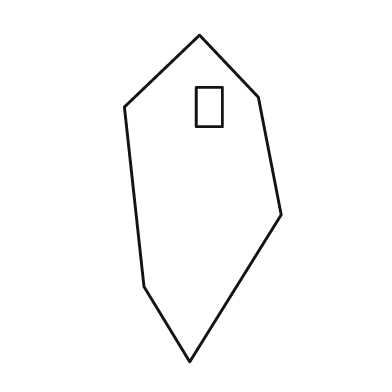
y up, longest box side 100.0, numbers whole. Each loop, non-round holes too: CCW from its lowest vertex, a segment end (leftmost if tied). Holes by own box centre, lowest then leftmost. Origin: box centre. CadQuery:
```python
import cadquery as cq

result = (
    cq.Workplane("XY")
    .moveTo(-4.0, -50.0)
    .lineTo(24.0, -5.0)
    .lineTo(17.0, 31.0)
    .lineTo(-1.0, 50.0)
    .lineTo(-24.0, 28.0)
    .lineTo(-18.0, -27.0)
    .close()
    .moveTo(-2.0, 22.0)
    .lineTo(6.0, 22.0)
    .lineTo(6.0, 34.0)
    .lineTo(-2.0, 34.0)
    .close()
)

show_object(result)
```